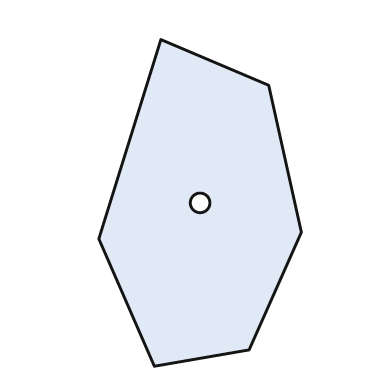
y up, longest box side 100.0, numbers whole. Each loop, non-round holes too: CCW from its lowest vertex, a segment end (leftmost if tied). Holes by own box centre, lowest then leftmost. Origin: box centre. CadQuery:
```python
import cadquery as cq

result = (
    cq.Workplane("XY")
    .moveTo(-14.0, -50.0)
    .lineTo(15.0, -45.0)
    .lineTo(31.0, -9.0)
    .lineTo(21.0, 36.0)
    .lineTo(-12.0, 50.0)
    .lineTo(-31.0, -11.0)
    .close()
    .moveTo(0.0, 0.0)
    .circle(3.0)
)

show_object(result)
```